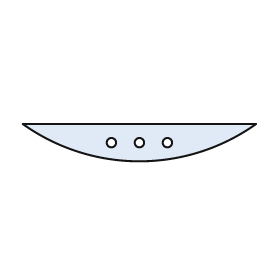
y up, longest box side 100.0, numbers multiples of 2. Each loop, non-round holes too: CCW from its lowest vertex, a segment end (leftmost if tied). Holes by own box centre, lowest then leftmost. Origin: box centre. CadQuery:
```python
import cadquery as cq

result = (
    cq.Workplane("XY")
    .moveTo(-50.0, 8.0)
    .threePointArc((0.0, -8.0), (50.0, 8.0))
    .close()
    .moveTo(-12.0, 0.0)
    .circle(2.0)
    .moveTo(0.0, 0.0)
    .circle(2.0)
    .moveTo(12.0, 0.0)
    .circle(2.0)
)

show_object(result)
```